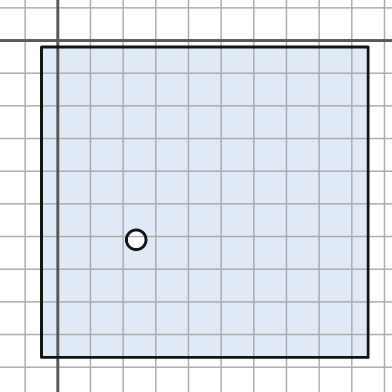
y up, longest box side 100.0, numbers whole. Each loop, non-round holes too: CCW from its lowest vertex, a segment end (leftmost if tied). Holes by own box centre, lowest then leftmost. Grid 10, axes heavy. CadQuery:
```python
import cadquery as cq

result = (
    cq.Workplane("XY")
    .moveTo(-5.0, -97.0)
    .lineTo(95.0, -97.0)
    .lineTo(95.0, -2.0)
    .lineTo(-5.0, -2.0)
    .close()
    .moveTo(24.0, -61.0)
    .circle(3.0)
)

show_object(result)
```